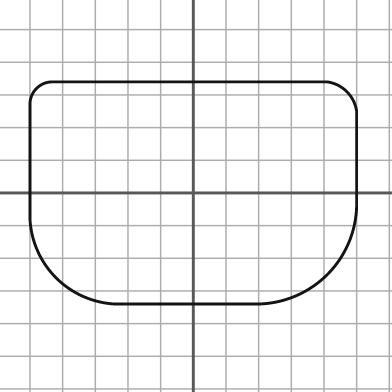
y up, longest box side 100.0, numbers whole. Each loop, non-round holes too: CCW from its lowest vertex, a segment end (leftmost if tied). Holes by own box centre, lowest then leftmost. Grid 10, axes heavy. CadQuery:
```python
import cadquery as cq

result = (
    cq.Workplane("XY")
    .moveTo(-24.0, -34.0)
    .lineTo(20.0, -34.0)
    .threePointArc((41.0, -25.0), (50.0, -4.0))
    .lineTo(50.0, 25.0)
    .threePointArc((47.0, 31.0), (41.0, 34.0))
    .lineTo(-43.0, 34.0)
    .threePointArc((-48.0, 32.0), (-50.0, 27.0))
    .lineTo(-50.0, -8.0)
    .threePointArc((-42.0, -26.0), (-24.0, -34.0))
    .close()
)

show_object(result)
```